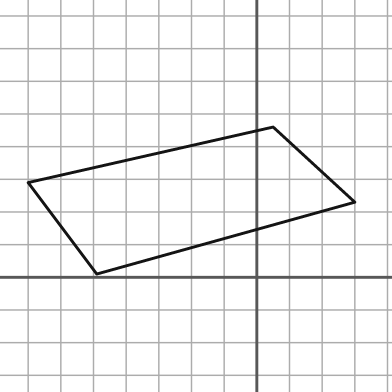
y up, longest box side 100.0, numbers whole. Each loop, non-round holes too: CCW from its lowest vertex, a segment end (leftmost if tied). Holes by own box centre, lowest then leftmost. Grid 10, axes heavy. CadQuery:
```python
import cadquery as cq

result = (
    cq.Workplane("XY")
    .moveTo(-49.0, 1.0)
    .lineTo(30.0, 23.0)
    .lineTo(5.0, 46.0)
    .lineTo(-70.0, 29.0)
    .close()
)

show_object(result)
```